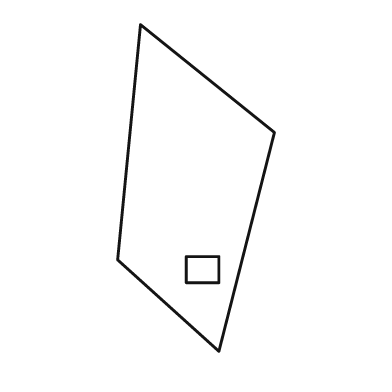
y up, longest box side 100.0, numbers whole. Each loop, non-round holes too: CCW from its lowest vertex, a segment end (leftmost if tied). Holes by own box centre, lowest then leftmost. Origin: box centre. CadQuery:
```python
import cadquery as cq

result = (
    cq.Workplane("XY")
    .moveTo(7.0, -50.0)
    .lineTo(24.0, 17.0)
    .lineTo(-17.0, 50.0)
    .lineTo(-24.0, -22.0)
    .close()
    .moveTo(-3.0, -29.0)
    .lineTo(7.0, -29.0)
    .lineTo(7.0, -21.0)
    .lineTo(-3.0, -21.0)
    .close()
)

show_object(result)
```